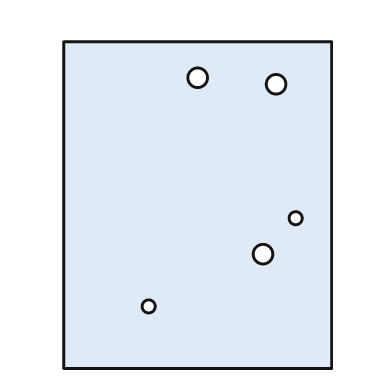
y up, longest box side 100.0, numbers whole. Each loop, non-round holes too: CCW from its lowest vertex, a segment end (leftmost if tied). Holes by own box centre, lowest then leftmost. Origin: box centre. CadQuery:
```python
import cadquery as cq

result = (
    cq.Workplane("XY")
    .moveTo(-41.0, -50.0)
    .lineTo(41.0, -50.0)
    .lineTo(41.0, 50.0)
    .lineTo(-41.0, 50.0)
    .close()
    .moveTo(-15.0, -31.0)
    .circle(2.0)
    .moveTo(20.0, -15.0)
    .circle(3.0)
    .moveTo(30.0, -4.0)
    .circle(2.0)
    .moveTo(24.0, 37.0)
    .circle(3.0)
    .moveTo(0.0, 39.0)
    .circle(3.0)
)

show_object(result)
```